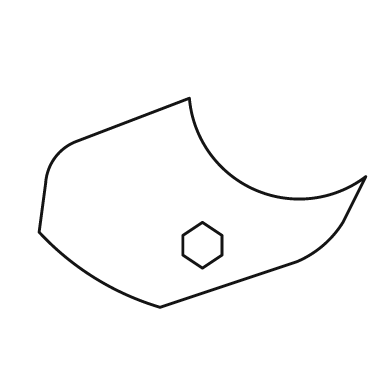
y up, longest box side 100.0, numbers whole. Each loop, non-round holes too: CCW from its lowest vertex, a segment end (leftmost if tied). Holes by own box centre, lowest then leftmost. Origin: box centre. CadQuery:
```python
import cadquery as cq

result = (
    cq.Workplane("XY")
    .moveTo(-13.0, -32.0)
    .lineTo(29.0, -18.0)
    .threePointArc((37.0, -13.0), (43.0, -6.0))
    .lineTo(50.0, 8.0)
    .threePointArc((16.0, 4.0), (-4.0, 32.0))
    .lineTo(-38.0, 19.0)
    .threePointArc((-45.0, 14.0), (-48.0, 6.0))
    .lineTo(-50.0, -9.0)
    .threePointArc((-33.0, -23.0), (-13.0, -32.0))
    .close()
    .moveTo(0.0, -20.0)
    .lineTo(6.0, -16.0)
    .lineTo(6.0, -10.0)
    .lineTo(0.0, -6.0)
    .lineTo(-6.0, -10.0)
    .lineTo(-6.0, -16.0)
    .close()
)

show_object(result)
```